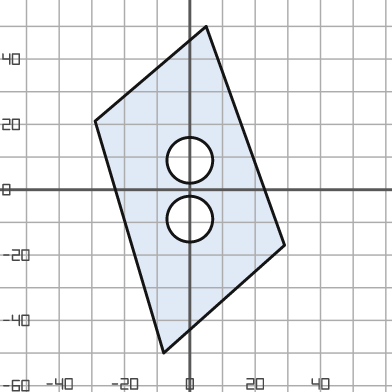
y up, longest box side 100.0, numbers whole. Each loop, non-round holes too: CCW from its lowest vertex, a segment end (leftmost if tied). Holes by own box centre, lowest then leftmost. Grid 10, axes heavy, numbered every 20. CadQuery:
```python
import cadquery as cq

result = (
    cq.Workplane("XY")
    .moveTo(-8.0, -50.0)
    .lineTo(29.0, -17.0)
    .lineTo(5.0, 50.0)
    .lineTo(-29.0, 21.0)
    .close()
    .moveTo(0.0, -9.0)
    .circle(7.0)
    .moveTo(0.0, 9.0)
    .circle(7.0)
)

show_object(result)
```